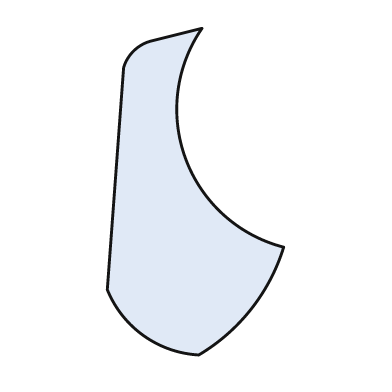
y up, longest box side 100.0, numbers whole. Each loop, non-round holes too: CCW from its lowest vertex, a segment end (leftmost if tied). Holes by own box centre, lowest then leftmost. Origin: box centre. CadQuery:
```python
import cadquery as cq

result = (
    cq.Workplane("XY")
    .moveTo(1.0, -50.0)
    .threePointArc((17.0, -36.0), (27.0, -17.0))
    .threePointArc((-3.0, 10.0), (2.0, 50.0))
    .lineTo(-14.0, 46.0)
    .threePointArc((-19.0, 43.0), (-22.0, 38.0))
    .lineTo(-27.0, -30.0)
    .threePointArc((-16.0, -44.0), (1.0, -50.0))
    .close()
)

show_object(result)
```